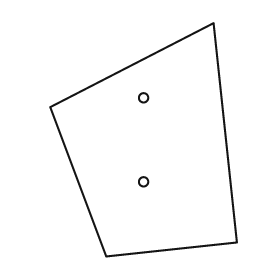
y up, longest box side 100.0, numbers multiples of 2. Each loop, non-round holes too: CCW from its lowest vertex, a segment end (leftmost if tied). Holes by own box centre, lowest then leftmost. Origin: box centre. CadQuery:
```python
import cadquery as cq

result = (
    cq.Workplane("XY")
    .moveTo(-16.0, -50.0)
    .lineTo(40.0, -44.0)
    .lineTo(30.0, 50.0)
    .lineTo(-40.0, 14.0)
    .close()
    .moveTo(0.0, -18.0)
    .circle(2.0)
    .moveTo(0.0, 18.0)
    .circle(2.0)
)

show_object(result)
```